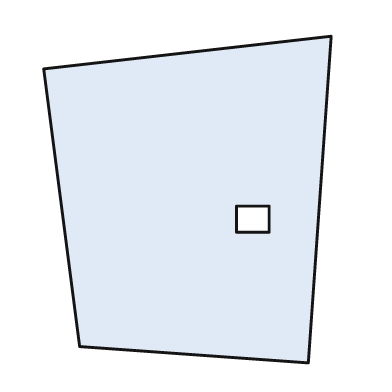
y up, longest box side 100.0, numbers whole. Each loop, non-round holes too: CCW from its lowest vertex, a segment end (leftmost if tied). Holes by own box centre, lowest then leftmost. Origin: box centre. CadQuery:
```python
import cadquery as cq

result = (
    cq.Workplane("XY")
    .moveTo(37.0, -50.0)
    .lineTo(44.0, 50.0)
    .lineTo(-44.0, 40.0)
    .lineTo(-33.0, -45.0)
    .close()
    .moveTo(15.0, -10.0)
    .lineTo(25.0, -10.0)
    .lineTo(25.0, -2.0)
    .lineTo(15.0, -2.0)
    .close()
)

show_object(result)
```